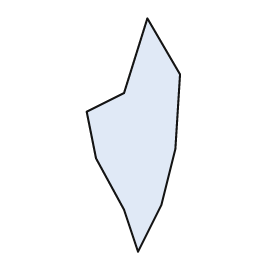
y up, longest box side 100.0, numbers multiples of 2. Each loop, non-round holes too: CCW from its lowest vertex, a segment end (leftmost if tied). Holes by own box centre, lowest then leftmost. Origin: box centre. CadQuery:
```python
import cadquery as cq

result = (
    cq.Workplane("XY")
    .moveTo(2.0, -50.0)
    .lineTo(12.0, -30.0)
    .lineTo(18.0, -6.0)
    .lineTo(20.0, 26.0)
    .lineTo(6.0, 50.0)
    .lineTo(-4.0, 18.0)
    .lineTo(-20.0, 10.0)
    .lineTo(-16.0, -10.0)
    .lineTo(-4.0, -32.0)
    .close()
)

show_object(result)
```